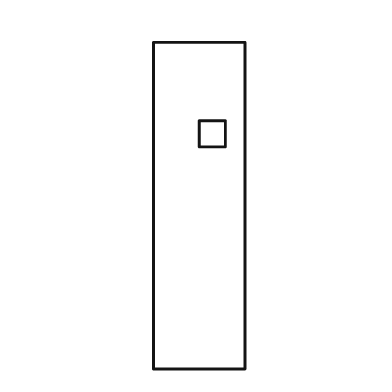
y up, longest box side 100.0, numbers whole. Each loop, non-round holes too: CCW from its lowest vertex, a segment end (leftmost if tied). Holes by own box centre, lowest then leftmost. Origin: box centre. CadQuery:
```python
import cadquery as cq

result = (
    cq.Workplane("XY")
    .moveTo(-14.0, -50.0)
    .lineTo(14.0, -50.0)
    .lineTo(14.0, 50.0)
    .lineTo(-14.0, 50.0)
    .close()
    .moveTo(0.0, 18.0)
    .lineTo(8.0, 18.0)
    .lineTo(8.0, 26.0)
    .lineTo(0.0, 26.0)
    .close()
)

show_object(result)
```